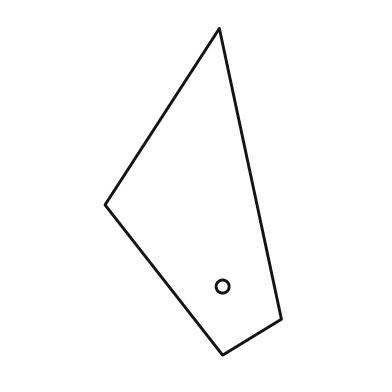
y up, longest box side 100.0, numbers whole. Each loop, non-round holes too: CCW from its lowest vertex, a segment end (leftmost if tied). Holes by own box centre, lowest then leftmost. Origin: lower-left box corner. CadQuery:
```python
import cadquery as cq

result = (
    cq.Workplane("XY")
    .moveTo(36.0, 0.0)
    .lineTo(54.0, 11.0)
    .lineTo(35.0, 100.0)
    .lineTo(0.0, 46.0)
    .close()
    .moveTo(36.0, 21.0)
    .circle(2.0)
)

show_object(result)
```